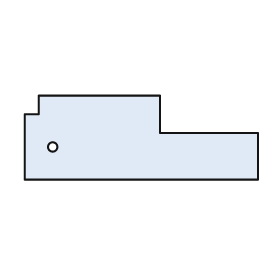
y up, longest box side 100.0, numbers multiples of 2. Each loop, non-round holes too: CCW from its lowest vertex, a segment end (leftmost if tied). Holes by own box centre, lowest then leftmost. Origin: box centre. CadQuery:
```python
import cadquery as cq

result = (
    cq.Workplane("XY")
    .moveTo(-50.0, -18.0)
    .lineTo(50.0, -18.0)
    .lineTo(50.0, 2.0)
    .lineTo(8.0, 2.0)
    .lineTo(8.0, 18.0)
    .lineTo(-44.0, 18.0)
    .lineTo(-44.0, 10.0)
    .lineTo(-50.0, 10.0)
    .close()
    .moveTo(-38.0, -4.0)
    .circle(2.0)
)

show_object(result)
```